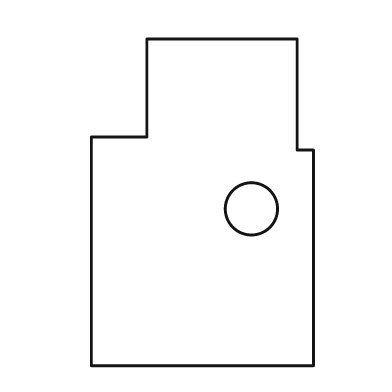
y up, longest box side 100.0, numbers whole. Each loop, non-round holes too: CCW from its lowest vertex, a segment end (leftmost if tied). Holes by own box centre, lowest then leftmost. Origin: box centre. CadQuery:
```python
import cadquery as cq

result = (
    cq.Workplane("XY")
    .moveTo(-34.0, -50.0)
    .lineTo(34.0, -50.0)
    .lineTo(34.0, 16.0)
    .lineTo(29.0, 16.0)
    .lineTo(29.0, 50.0)
    .lineTo(-17.0, 50.0)
    .lineTo(-17.0, 20.0)
    .lineTo(-34.0, 20.0)
    .close()
    .moveTo(15.0, -2.0)
    .circle(8.0)
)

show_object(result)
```